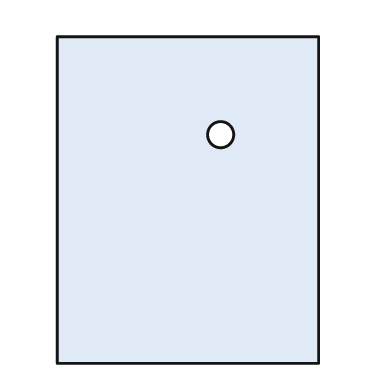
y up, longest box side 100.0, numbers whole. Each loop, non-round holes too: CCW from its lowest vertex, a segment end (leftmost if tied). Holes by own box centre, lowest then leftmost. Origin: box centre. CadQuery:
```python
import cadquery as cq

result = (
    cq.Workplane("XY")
    .moveTo(-40.0, -50.0)
    .lineTo(40.0, -50.0)
    .lineTo(40.0, 50.0)
    .lineTo(-40.0, 50.0)
    .close()
    .moveTo(10.0, 20.0)
    .circle(4.0)
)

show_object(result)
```